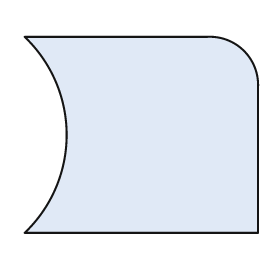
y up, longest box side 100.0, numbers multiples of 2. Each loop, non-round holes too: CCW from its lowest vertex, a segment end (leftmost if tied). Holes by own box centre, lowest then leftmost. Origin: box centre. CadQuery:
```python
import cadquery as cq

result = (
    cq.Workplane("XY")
    .moveTo(-50.0, -42.0)
    .lineTo(50.0, -42.0)
    .lineTo(50.0, 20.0)
    .threePointArc((44.0, 36.0), (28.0, 42.0))
    .lineTo(-50.0, 42.0)
    .threePointArc((-32.0, 0.0), (-50.0, -42.0))
    .close()
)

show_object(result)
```